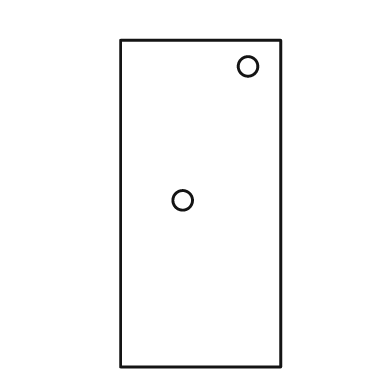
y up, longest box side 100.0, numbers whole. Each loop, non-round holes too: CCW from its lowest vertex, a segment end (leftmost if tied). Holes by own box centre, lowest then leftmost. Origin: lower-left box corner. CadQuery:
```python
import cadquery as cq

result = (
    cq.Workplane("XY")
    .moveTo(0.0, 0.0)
    .lineTo(49.0, 0.0)
    .lineTo(49.0, 100.0)
    .lineTo(0.0, 100.0)
    .close()
    .moveTo(19.0, 51.0)
    .circle(3.0)
    .moveTo(39.0, 92.0)
    .circle(3.0)
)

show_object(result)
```